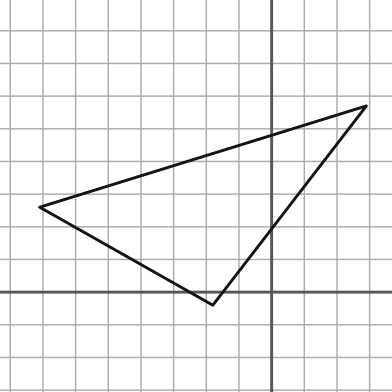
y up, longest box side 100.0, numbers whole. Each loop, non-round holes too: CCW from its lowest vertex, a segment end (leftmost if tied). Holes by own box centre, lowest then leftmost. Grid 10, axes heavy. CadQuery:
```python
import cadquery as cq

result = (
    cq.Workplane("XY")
    .moveTo(-18.0, -4.0)
    .lineTo(29.0, 57.0)
    .lineTo(-71.0, 26.0)
    .close()
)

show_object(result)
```